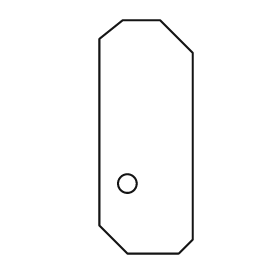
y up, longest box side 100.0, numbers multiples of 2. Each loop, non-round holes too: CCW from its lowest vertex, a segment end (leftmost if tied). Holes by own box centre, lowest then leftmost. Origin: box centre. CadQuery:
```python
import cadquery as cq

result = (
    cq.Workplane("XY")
    .moveTo(-8.0, -50.0)
    .lineTo(14.0, -50.0)
    .lineTo(20.0, -44.0)
    .lineTo(20.0, 36.0)
    .lineTo(6.0, 50.0)
    .lineTo(-10.0, 50.0)
    .lineTo(-20.0, 42.0)
    .lineTo(-20.0, -38.0)
    .close()
    .moveTo(-8.0, -20.0)
    .circle(4.0)
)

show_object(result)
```